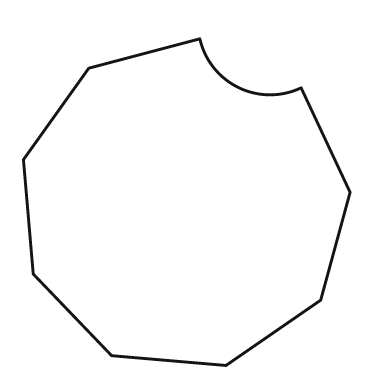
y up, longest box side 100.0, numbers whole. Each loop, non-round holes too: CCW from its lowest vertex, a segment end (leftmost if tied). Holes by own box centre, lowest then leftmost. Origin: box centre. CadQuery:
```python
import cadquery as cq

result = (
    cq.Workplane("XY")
    .moveTo(12.0, -50.0)
    .lineTo(41.0, -30.0)
    .lineTo(50.0, 3.0)
    .lineTo(35.0, 35.0)
    .threePointArc((16.0, 35.0), (4.0, 50.0))
    .lineTo(-30.0, 41.0)
    .lineTo(-50.0, 13.0)
    .lineTo(-47.0, -22.0)
    .lineTo(-23.0, -47.0)
    .close()
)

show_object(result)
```